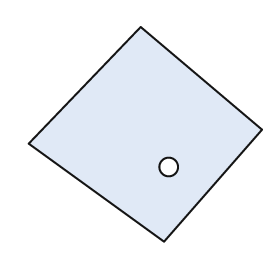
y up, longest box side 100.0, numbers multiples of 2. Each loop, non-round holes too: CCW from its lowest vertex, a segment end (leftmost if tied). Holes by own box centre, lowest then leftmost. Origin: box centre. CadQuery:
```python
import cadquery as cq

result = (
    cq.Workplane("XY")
    .moveTo(8.0, -46.0)
    .lineTo(50.0, 2.0)
    .lineTo(-2.0, 46.0)
    .lineTo(-50.0, -4.0)
    .close()
    .moveTo(10.0, -14.0)
    .circle(4.0)
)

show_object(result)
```